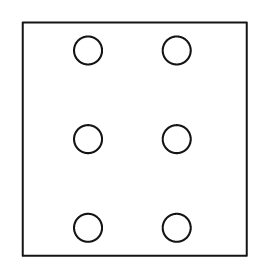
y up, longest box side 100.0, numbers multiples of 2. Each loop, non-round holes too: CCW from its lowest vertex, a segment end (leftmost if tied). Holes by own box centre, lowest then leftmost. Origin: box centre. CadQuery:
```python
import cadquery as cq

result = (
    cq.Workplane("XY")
    .moveTo(-48.0, -50.0)
    .lineTo(48.0, -50.0)
    .lineTo(48.0, 50.0)
    .lineTo(-48.0, 50.0)
    .close()
    .moveTo(-20.0, -38.0)
    .circle(6.0)
    .moveTo(18.0, -38.0)
    .circle(6.0)
    .moveTo(-20.0, 0.0)
    .circle(6.0)
    .moveTo(18.0, 0.0)
    .circle(6.0)
    .moveTo(-20.0, 38.0)
    .circle(6.0)
    .moveTo(18.0, 38.0)
    .circle(6.0)
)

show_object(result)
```